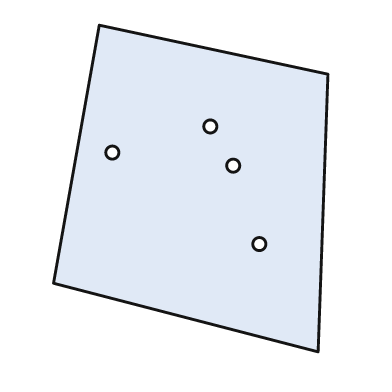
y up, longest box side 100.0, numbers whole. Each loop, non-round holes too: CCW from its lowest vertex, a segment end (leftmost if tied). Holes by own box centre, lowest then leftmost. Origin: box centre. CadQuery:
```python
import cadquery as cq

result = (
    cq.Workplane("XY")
    .moveTo(39.0, -50.0)
    .lineTo(42.0, 35.0)
    .lineTo(-28.0, 50.0)
    .lineTo(-42.0, -29.0)
    .close()
    .moveTo(21.0, -17.0)
    .circle(2.0)
    .moveTo(13.0, 7.0)
    .circle(2.0)
    .moveTo(-24.0, 11.0)
    .circle(2.0)
    .moveTo(6.0, 19.0)
    .circle(2.0)
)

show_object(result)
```